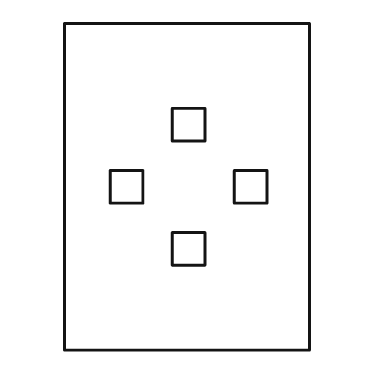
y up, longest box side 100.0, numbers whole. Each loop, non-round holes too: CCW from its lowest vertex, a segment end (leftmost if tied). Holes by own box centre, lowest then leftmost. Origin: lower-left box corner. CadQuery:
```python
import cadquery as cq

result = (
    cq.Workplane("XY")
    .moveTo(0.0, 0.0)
    .lineTo(75.0, 0.0)
    .lineTo(75.0, 100.0)
    .lineTo(0.0, 100.0)
    .close()
    .moveTo(33.0, 26.0)
    .lineTo(43.0, 26.0)
    .lineTo(43.0, 36.0)
    .lineTo(33.0, 36.0)
    .close()
    .moveTo(14.0, 45.0)
    .lineTo(24.0, 45.0)
    .lineTo(24.0, 55.0)
    .lineTo(14.0, 55.0)
    .close()
    .moveTo(52.0, 45.0)
    .lineTo(62.0, 45.0)
    .lineTo(62.0, 55.0)
    .lineTo(52.0, 55.0)
    .close()
    .moveTo(33.0, 64.0)
    .lineTo(43.0, 64.0)
    .lineTo(43.0, 74.0)
    .lineTo(33.0, 74.0)
    .close()
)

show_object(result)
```